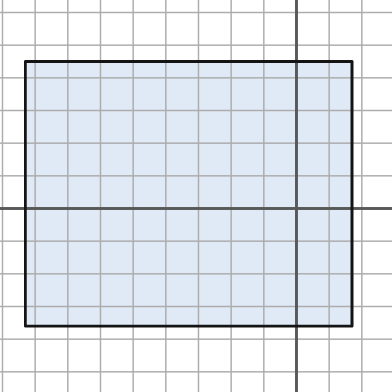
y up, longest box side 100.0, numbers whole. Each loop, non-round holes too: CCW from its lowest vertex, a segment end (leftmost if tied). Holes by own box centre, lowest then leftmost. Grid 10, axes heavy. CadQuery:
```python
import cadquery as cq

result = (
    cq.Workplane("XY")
    .moveTo(-83.0, -36.0)
    .lineTo(17.0, -36.0)
    .lineTo(17.0, 45.0)
    .lineTo(-83.0, 45.0)
    .close()
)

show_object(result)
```